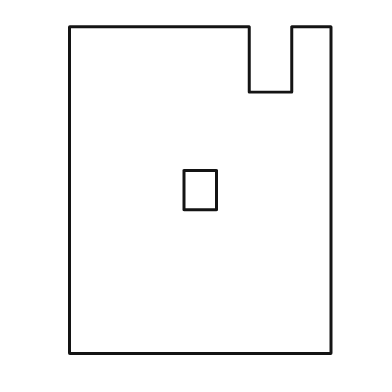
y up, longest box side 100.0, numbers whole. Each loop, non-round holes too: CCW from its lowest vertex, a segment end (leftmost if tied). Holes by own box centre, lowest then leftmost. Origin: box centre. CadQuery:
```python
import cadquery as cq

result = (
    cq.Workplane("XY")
    .moveTo(-40.0, -50.0)
    .lineTo(40.0, -50.0)
    .lineTo(40.0, 50.0)
    .lineTo(28.0, 50.0)
    .lineTo(28.0, 30.0)
    .lineTo(15.0, 30.0)
    .lineTo(15.0, 50.0)
    .lineTo(-40.0, 50.0)
    .close()
    .moveTo(-5.0, -6.0)
    .lineTo(5.0, -6.0)
    .lineTo(5.0, 6.0)
    .lineTo(-5.0, 6.0)
    .close()
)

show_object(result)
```